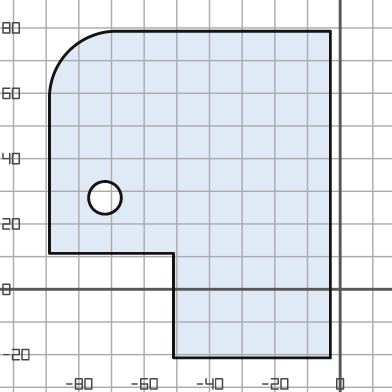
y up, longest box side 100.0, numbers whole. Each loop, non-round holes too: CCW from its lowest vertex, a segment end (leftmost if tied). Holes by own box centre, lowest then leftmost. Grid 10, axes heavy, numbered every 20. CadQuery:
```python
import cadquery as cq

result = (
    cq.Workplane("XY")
    .moveTo(-51.0, -21.0)
    .lineTo(-3.0, -21.0)
    .lineTo(-3.0, 79.0)
    .lineTo(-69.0, 79.0)
    .threePointArc((-83.0, 73.0), (-89.0, 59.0))
    .lineTo(-89.0, 11.0)
    .lineTo(-51.0, 11.0)
    .close()
    .moveTo(-72.0, 28.0)
    .circle(5.0)
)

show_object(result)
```